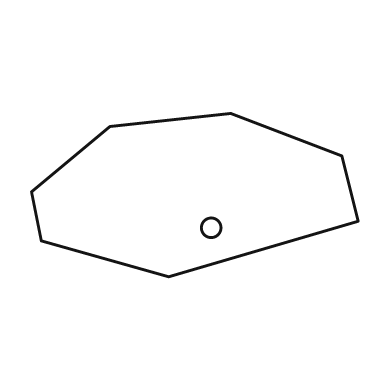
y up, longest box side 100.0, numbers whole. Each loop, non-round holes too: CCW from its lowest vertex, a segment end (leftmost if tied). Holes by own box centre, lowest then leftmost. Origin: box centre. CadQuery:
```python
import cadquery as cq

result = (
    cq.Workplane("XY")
    .moveTo(-8.0, -25.0)
    .lineTo(50.0, -8.0)
    .lineTo(45.0, 12.0)
    .lineTo(11.0, 25.0)
    .lineTo(-26.0, 21.0)
    .lineTo(-50.0, 1.0)
    .lineTo(-47.0, -14.0)
    .close()
    .moveTo(5.0, -10.0)
    .circle(3.0)
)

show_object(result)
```